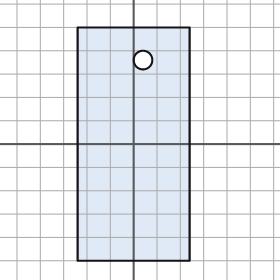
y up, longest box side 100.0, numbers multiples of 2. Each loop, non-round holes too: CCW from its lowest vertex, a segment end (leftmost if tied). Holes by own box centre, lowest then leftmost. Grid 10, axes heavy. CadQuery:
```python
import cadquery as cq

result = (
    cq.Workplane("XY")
    .moveTo(-24.0, -50.0)
    .lineTo(24.0, -50.0)
    .lineTo(24.0, 50.0)
    .lineTo(-24.0, 50.0)
    .close()
    .moveTo(4.0, 36.0)
    .circle(4.0)
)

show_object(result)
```